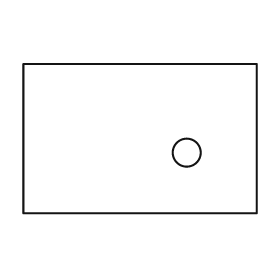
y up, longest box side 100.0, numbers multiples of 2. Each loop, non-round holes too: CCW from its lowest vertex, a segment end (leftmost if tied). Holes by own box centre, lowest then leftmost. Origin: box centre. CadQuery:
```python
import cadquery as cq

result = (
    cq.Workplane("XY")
    .moveTo(-50.0, -32.0)
    .lineTo(50.0, -32.0)
    .lineTo(50.0, 32.0)
    .lineTo(-50.0, 32.0)
    .close()
    .moveTo(20.0, -6.0)
    .circle(6.0)
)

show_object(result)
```